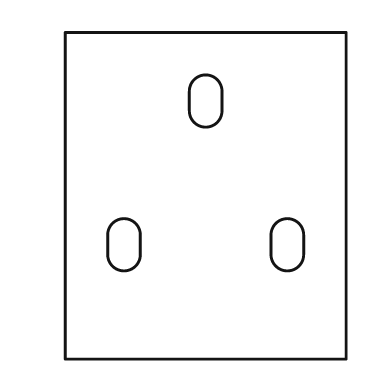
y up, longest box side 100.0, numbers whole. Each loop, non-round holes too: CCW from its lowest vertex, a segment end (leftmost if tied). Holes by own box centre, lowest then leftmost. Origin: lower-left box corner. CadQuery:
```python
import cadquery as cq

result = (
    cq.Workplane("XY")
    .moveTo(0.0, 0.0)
    .lineTo(86.0, 0.0)
    .lineTo(86.0, 100.0)
    .lineTo(0.0, 100.0)
    .close()
    .moveTo(13.0, 32.0)
    .threePointArc((18.0, 27.0), (23.0, 32.0))
    .lineTo(23.0, 38.0)
    .threePointArc((18.0, 43.0), (13.0, 38.0))
    .close()
    .moveTo(63.0, 32.0)
    .threePointArc((68.0, 27.0), (73.0, 32.0))
    .lineTo(73.0, 38.0)
    .threePointArc((68.0, 43.0), (63.0, 38.0))
    .close()
    .moveTo(38.0, 76.0)
    .threePointArc((43.0, 71.0), (48.0, 76.0))
    .lineTo(48.0, 82.0)
    .threePointArc((43.0, 87.0), (38.0, 82.0))
    .close()
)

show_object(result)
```